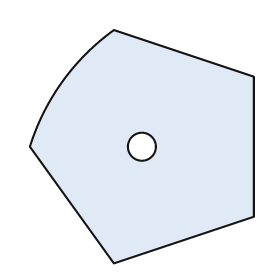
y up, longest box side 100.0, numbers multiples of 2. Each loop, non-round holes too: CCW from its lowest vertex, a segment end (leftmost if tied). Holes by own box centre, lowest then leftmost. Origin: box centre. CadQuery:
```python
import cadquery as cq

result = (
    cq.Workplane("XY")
    .moveTo(-12.0, -50.0)
    .lineTo(48.0, -30.0)
    .lineTo(48.0, 30.0)
    .lineTo(-12.0, 50.0)
    .threePointArc((-34.0, 28.0), (-48.0, 0.0))
    .close()
    .moveTo(0.0, 0.0)
    .circle(6.0)
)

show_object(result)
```